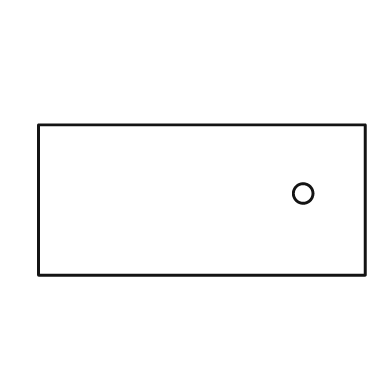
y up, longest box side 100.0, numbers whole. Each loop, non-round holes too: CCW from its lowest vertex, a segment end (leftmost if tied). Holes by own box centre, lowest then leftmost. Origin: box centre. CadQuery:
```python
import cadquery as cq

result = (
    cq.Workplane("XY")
    .moveTo(-50.0, -23.0)
    .lineTo(50.0, -23.0)
    .lineTo(50.0, 23.0)
    .lineTo(-50.0, 23.0)
    .close()
    .moveTo(31.0, 2.0)
    .circle(3.0)
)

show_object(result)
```